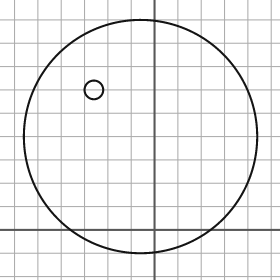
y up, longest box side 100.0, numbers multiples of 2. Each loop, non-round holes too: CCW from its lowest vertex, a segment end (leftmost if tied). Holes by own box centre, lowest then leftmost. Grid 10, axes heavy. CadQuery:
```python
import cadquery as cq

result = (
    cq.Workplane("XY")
    .moveTo(-6.0, 40.0)
    .circle(50.0)
    .moveTo(-26.0, 60.0)
    .circle(4.0)
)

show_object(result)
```